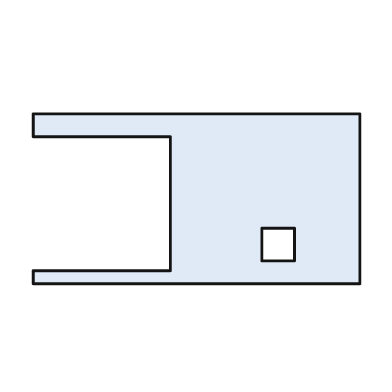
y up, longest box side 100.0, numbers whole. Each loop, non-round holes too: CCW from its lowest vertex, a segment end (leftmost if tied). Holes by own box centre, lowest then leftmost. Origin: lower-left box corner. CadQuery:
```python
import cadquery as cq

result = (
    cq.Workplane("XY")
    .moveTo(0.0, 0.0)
    .lineTo(100.0, 0.0)
    .lineTo(100.0, 52.0)
    .lineTo(0.0, 52.0)
    .lineTo(0.0, 45.0)
    .lineTo(42.0, 45.0)
    .lineTo(42.0, 4.0)
    .lineTo(0.0, 4.0)
    .close()
    .moveTo(70.0, 7.0)
    .lineTo(80.0, 7.0)
    .lineTo(80.0, 17.0)
    .lineTo(70.0, 17.0)
    .close()
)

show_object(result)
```